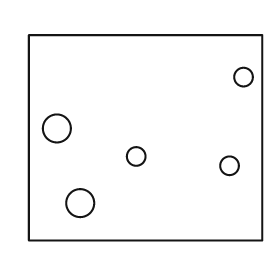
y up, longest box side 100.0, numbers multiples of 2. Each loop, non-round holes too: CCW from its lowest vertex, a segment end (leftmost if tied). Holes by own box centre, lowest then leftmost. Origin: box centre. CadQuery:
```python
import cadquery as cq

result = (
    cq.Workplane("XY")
    .moveTo(-50.0, -44.0)
    .lineTo(50.0, -44.0)
    .lineTo(50.0, 44.0)
    .lineTo(-50.0, 44.0)
    .close()
    .moveTo(-28.0, -28.0)
    .circle(6.0)
    .moveTo(36.0, -12.0)
    .circle(4.0)
    .moveTo(-4.0, -8.0)
    .circle(4.0)
    .moveTo(-38.0, 4.0)
    .circle(6.0)
    .moveTo(42.0, 26.0)
    .circle(4.0)
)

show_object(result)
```